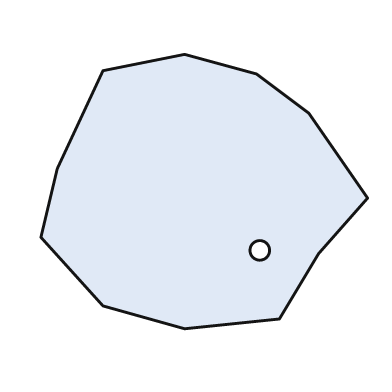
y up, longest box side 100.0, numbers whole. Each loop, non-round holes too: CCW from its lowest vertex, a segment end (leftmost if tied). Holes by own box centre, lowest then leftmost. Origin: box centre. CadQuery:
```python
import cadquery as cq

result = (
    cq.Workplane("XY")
    .moveTo(-6.0, -42.0)
    .lineTo(23.0, -39.0)
    .lineTo(35.0, -19.0)
    .lineTo(50.0, -2.0)
    .lineTo(32.0, 24.0)
    .lineTo(16.0, 36.0)
    .lineTo(-6.0, 42.0)
    .lineTo(-31.0, 37.0)
    .lineTo(-45.0, 7.0)
    .lineTo(-50.0, -14.0)
    .lineTo(-31.0, -35.0)
    .close()
    .moveTo(17.0, -18.0)
    .circle(3.0)
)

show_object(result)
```